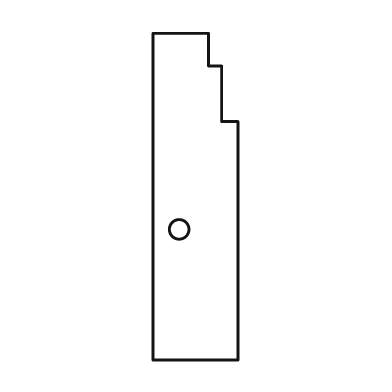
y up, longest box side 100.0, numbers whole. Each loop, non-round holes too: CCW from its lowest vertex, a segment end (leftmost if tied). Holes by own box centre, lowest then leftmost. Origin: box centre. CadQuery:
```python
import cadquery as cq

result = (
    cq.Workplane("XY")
    .moveTo(-13.0, -50.0)
    .lineTo(13.0, -50.0)
    .lineTo(13.0, 23.0)
    .lineTo(8.0, 23.0)
    .lineTo(8.0, 40.0)
    .lineTo(4.0, 40.0)
    .lineTo(4.0, 50.0)
    .lineTo(-13.0, 50.0)
    .close()
    .moveTo(-5.0, -10.0)
    .circle(3.0)
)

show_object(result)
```